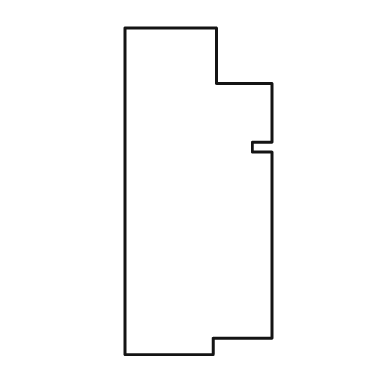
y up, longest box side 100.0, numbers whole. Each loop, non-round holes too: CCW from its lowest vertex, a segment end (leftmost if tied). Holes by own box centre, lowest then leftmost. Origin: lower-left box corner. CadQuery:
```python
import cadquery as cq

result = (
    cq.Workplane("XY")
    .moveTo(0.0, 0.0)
    .lineTo(27.0, 0.0)
    .lineTo(27.0, 5.0)
    .lineTo(45.0, 5.0)
    .lineTo(45.0, 62.0)
    .lineTo(39.0, 62.0)
    .lineTo(39.0, 65.0)
    .lineTo(45.0, 65.0)
    .lineTo(45.0, 83.0)
    .lineTo(28.0, 83.0)
    .lineTo(28.0, 100.0)
    .lineTo(0.0, 100.0)
    .close()
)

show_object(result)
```